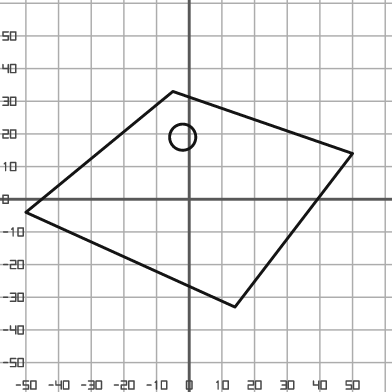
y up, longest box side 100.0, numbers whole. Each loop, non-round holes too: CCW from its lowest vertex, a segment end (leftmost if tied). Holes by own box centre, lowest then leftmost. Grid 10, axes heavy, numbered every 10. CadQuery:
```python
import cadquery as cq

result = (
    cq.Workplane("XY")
    .moveTo(14.0, -33.0)
    .lineTo(50.0, 14.0)
    .lineTo(-5.0, 33.0)
    .lineTo(-50.0, -4.0)
    .close()
    .moveTo(-2.0, 19.0)
    .circle(4.0)
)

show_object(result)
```